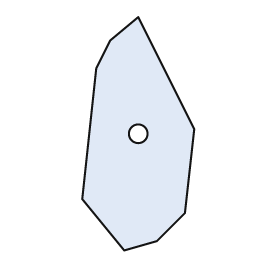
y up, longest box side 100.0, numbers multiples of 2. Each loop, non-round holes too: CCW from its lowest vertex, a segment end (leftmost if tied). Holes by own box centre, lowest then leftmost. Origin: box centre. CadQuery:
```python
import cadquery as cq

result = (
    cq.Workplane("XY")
    .moveTo(-6.0, -50.0)
    .lineTo(8.0, -46.0)
    .lineTo(20.0, -34.0)
    .lineTo(24.0, 2.0)
    .lineTo(0.0, 50.0)
    .lineTo(-12.0, 40.0)
    .lineTo(-18.0, 28.0)
    .lineTo(-24.0, -28.0)
    .close()
    .moveTo(0.0, 0.0)
    .circle(4.0)
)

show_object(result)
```